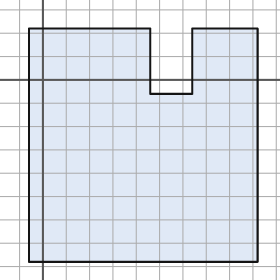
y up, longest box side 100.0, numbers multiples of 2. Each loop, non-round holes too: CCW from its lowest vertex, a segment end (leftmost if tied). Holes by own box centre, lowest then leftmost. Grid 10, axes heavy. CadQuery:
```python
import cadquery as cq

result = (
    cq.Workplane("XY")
    .moveTo(-6.0, -78.0)
    .lineTo(92.0, -78.0)
    .lineTo(92.0, 22.0)
    .lineTo(64.0, 22.0)
    .lineTo(64.0, -6.0)
    .lineTo(46.0, -6.0)
    .lineTo(46.0, 22.0)
    .lineTo(-6.0, 22.0)
    .close()
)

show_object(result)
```